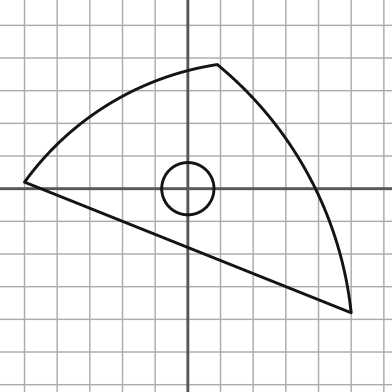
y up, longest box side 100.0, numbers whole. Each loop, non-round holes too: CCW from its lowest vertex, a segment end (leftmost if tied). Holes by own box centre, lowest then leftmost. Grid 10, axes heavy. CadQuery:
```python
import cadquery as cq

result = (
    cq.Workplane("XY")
    .moveTo(50.0, -38.0)
    .threePointArc((37.0, 4.0), (9.0, 38.0))
    .threePointArc((-24.0, 26.0), (-50.0, 2.0))
    .close()
    .moveTo(0.0, 0.0)
    .circle(8.0)
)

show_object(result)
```